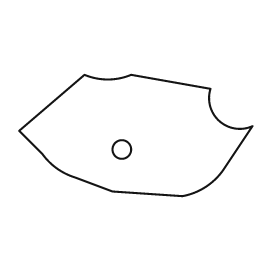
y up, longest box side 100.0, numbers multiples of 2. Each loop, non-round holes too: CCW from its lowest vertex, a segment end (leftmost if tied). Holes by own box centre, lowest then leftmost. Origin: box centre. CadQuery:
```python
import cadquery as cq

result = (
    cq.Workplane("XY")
    .moveTo(20.0, -26.0)
    .threePointArc((30.0, -22.0), (38.0, -14.0))
    .lineTo(50.0, 4.0)
    .threePointArc((36.0, 6.0), (32.0, 20.0))
    .lineTo(-2.0, 26.0)
    .threePointArc((-12.0, 24.0), (-22.0, 26.0))
    .lineTo(-50.0, 2.0)
    .lineTo(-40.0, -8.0)
    .threePointArc((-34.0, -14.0), (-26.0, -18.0))
    .lineTo(-10.0, -24.0)
    .close()
    .moveTo(-6.0, -6.0)
    .circle(4.0)
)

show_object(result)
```